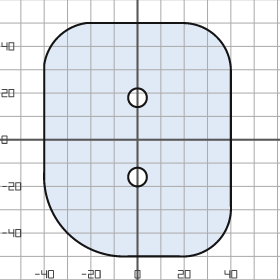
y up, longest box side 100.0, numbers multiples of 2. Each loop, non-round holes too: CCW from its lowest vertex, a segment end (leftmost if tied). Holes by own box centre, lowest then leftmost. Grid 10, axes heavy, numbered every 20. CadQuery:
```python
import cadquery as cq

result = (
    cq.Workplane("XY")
    .moveTo(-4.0, -50.0)
    .lineTo(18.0, -50.0)
    .threePointArc((34.0, -44.0), (40.0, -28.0))
    .lineTo(40.0, 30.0)
    .threePointArc((34.0, 44.0), (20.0, 50.0))
    .lineTo(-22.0, 50.0)
    .threePointArc((-34.0, 44.0), (-40.0, 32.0))
    .lineTo(-40.0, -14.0)
    .threePointArc((-30.0, -40.0), (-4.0, -50.0))
    .close()
    .moveTo(0.0, -16.0)
    .circle(4.0)
    .moveTo(0.0, 18.0)
    .circle(4.0)
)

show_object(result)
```